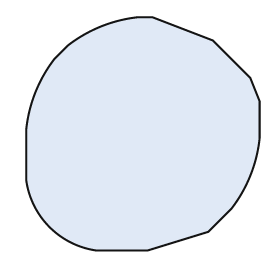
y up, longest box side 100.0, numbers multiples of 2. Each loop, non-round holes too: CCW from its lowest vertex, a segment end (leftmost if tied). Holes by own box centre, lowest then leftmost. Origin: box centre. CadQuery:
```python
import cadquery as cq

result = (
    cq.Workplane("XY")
    .moveTo(-20.0, -50.0)
    .lineTo(2.0, -50.0)
    .lineTo(28.0, -42.0)
    .lineTo(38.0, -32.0)
    .threePointArc((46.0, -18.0), (50.0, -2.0))
    .lineTo(50.0, 14.0)
    .lineTo(46.0, 24.0)
    .lineTo(30.0, 40.0)
    .lineTo(4.0, 50.0)
    .lineTo(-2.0, 50.0)
    .threePointArc((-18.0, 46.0), (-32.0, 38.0))
    .lineTo(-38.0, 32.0)
    .threePointArc((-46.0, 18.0), (-50.0, 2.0))
    .lineTo(-50.0, -20.0)
    .threePointArc((-40.0, -40.0), (-20.0, -50.0))
    .close()
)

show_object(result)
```